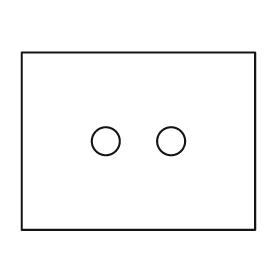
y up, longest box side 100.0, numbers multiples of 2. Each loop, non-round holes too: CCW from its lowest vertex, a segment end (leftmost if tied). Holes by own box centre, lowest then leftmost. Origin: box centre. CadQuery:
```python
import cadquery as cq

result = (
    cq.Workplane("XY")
    .moveTo(-50.0, -38.0)
    .lineTo(50.0, -38.0)
    .lineTo(50.0, 38.0)
    .lineTo(-50.0, 38.0)
    .close()
    .moveTo(-14.0, 0.0)
    .circle(6.0)
    .moveTo(14.0, 0.0)
    .circle(6.0)
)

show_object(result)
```